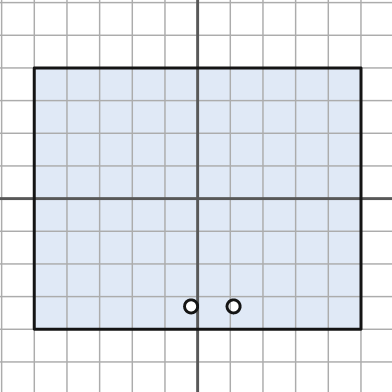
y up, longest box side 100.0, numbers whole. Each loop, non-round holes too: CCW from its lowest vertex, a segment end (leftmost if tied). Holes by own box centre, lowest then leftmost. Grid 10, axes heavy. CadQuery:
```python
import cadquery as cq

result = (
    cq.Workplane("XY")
    .moveTo(-50.0, -40.0)
    .lineTo(50.0, -40.0)
    .lineTo(50.0, 40.0)
    .lineTo(-50.0, 40.0)
    .close()
    .moveTo(-2.0, -33.0)
    .circle(2.0)
    .moveTo(11.0, -33.0)
    .circle(2.0)
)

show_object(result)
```